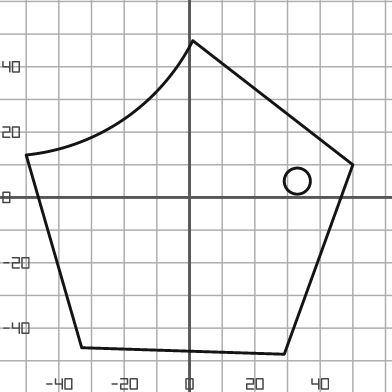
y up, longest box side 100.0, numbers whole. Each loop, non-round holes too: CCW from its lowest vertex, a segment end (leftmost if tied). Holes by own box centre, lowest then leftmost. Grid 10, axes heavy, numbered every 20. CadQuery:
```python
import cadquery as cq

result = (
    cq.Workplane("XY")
    .moveTo(29.0, -48.0)
    .lineTo(50.0, 10.0)
    .lineTo(1.0, 48.0)
    .threePointArc((-20.0, 24.0), (-50.0, 13.0))
    .lineTo(-33.0, -46.0)
    .close()
    .moveTo(33.0, 5.0)
    .circle(4.0)
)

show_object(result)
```